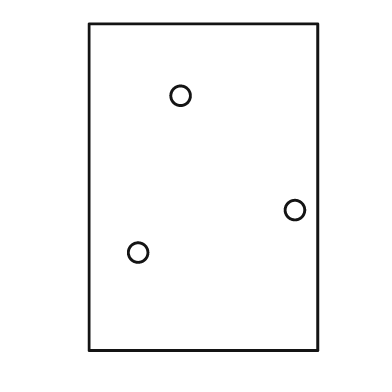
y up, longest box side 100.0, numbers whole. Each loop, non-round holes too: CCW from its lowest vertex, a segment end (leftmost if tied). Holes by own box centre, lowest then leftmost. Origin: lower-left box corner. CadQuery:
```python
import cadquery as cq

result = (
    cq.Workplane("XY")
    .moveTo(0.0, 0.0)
    .lineTo(70.0, 0.0)
    .lineTo(70.0, 100.0)
    .lineTo(0.0, 100.0)
    .close()
    .moveTo(15.0, 30.0)
    .circle(3.0)
    .moveTo(63.0, 43.0)
    .circle(3.0)
    .moveTo(28.0, 78.0)
    .circle(3.0)
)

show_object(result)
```